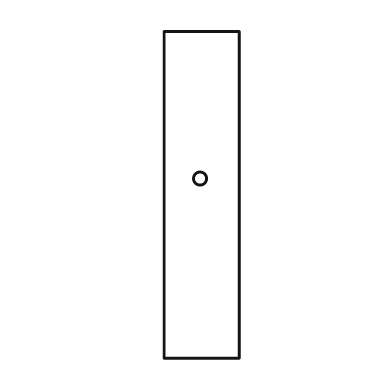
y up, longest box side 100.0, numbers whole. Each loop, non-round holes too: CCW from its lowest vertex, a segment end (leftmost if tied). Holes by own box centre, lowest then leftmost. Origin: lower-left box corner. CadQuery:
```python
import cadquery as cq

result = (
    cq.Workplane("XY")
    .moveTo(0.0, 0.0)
    .lineTo(23.0, 0.0)
    .lineTo(23.0, 100.0)
    .lineTo(0.0, 100.0)
    .close()
    .moveTo(11.0, 55.0)
    .circle(2.0)
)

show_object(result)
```